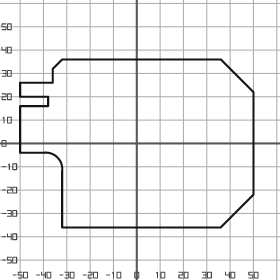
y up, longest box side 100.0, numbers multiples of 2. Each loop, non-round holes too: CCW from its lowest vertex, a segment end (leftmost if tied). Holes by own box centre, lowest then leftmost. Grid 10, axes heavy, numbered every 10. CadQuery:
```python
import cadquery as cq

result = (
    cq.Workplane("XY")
    .moveTo(-32.0, -36.0)
    .lineTo(36.0, -36.0)
    .lineTo(50.0, -22.0)
    .lineTo(50.0, 22.0)
    .lineTo(36.0, 36.0)
    .lineTo(-32.0, 36.0)
    .lineTo(-36.0, 32.0)
    .lineTo(-36.0, 26.0)
    .lineTo(-50.0, 26.0)
    .lineTo(-50.0, 20.0)
    .lineTo(-38.0, 20.0)
    .lineTo(-38.0, 16.0)
    .lineTo(-50.0, 16.0)
    .lineTo(-50.0, -4.0)
    .lineTo(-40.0, -4.0)
    .threePointArc((-34.0, -6.0), (-32.0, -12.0))
    .close()
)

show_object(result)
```